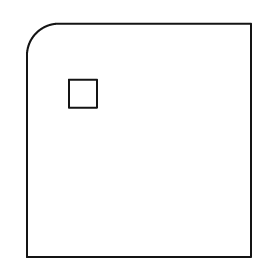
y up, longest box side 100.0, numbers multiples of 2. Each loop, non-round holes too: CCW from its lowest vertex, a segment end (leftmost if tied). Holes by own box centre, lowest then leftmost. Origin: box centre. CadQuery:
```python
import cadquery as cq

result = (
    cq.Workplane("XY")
    .moveTo(-48.0, -50.0)
    .lineTo(48.0, -50.0)
    .lineTo(48.0, 50.0)
    .lineTo(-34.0, 50.0)
    .threePointArc((-44.0, 46.0), (-48.0, 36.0))
    .close()
    .moveTo(-30.0, 14.0)
    .lineTo(-18.0, 14.0)
    .lineTo(-18.0, 26.0)
    .lineTo(-30.0, 26.0)
    .close()
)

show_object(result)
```